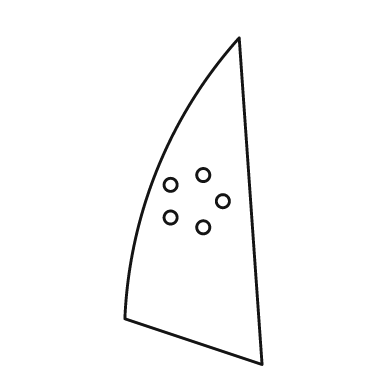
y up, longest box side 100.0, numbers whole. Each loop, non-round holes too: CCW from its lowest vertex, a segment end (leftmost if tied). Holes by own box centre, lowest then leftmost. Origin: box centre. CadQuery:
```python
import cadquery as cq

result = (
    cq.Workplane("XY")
    .moveTo(21.0, -50.0)
    .lineTo(14.0, 50.0)
    .threePointArc((-11.0, 10.0), (-21.0, -36.0))
    .close()
    .moveTo(3.0, -8.0)
    .circle(2.0)
    .moveTo(-7.0, -5.0)
    .circle(2.0)
    .moveTo(9.0, 0.0)
    .circle(2.0)
    .moveTo(-7.0, 5.0)
    .circle(2.0)
    .moveTo(3.0, 8.0)
    .circle(2.0)
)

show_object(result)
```